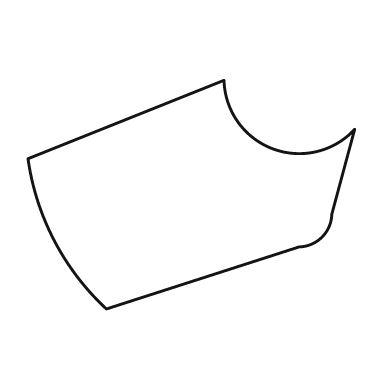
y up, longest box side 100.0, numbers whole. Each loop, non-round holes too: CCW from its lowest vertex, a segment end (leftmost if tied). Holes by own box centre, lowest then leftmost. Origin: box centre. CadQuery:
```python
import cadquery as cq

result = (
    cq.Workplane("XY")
    .moveTo(-26.0, -35.0)
    .lineTo(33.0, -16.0)
    .threePointArc((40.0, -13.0), (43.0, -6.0))
    .lineTo(50.0, 20.0)
    .threePointArc((25.0, 14.0), (10.0, 35.0))
    .lineTo(-50.0, 11.0)
    .threePointArc((-42.0, -14.0), (-26.0, -35.0))
    .close()
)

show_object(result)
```